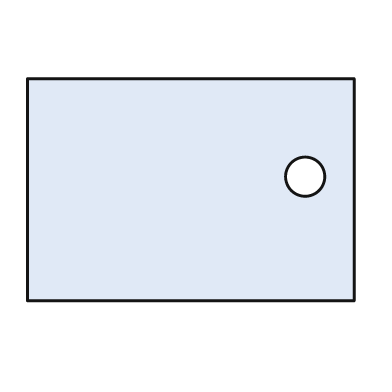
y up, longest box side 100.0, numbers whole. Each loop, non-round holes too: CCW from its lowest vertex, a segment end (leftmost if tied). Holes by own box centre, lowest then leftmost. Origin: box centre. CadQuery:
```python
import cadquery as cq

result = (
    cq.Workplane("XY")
    .moveTo(-50.0, -34.0)
    .lineTo(50.0, -34.0)
    .lineTo(50.0, 34.0)
    .lineTo(-50.0, 34.0)
    .close()
    .moveTo(35.0, 4.0)
    .circle(6.0)
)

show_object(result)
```